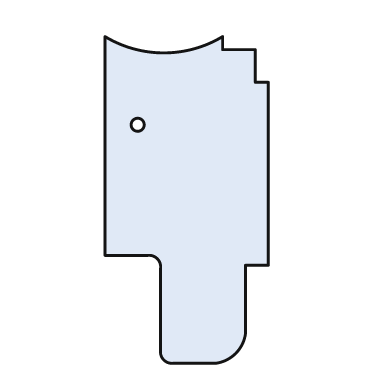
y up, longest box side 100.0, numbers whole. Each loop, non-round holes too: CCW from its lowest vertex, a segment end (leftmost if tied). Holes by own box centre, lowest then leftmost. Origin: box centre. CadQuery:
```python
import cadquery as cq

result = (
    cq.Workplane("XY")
    .moveTo(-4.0, -50.0)
    .lineTo(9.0, -50.0)
    .threePointArc((15.0, -47.0), (18.0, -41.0))
    .lineTo(18.0, -20.0)
    .lineTo(25.0, -20.0)
    .lineTo(25.0, 36.0)
    .lineTo(21.0, 36.0)
    .lineTo(21.0, 46.0)
    .lineTo(11.0, 46.0)
    .lineTo(11.0, 50.0)
    .threePointArc((-7.0, 45.0), (-25.0, 50.0))
    .lineTo(-25.0, -17.0)
    .lineTo(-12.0, -17.0)
    .threePointArc((-9.0, -18.0), (-8.0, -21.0))
    .lineTo(-8.0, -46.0)
    .threePointArc((-7.0, -49.0), (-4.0, -50.0))
    .close()
    .moveTo(-15.0, 23.0)
    .circle(2.0)
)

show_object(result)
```